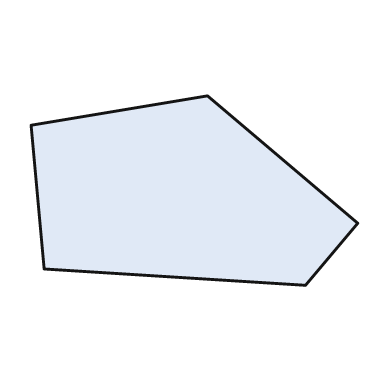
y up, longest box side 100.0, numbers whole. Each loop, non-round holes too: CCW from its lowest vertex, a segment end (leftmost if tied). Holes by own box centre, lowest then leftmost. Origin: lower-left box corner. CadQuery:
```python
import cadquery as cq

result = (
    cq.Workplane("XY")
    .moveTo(84.0, 0.0)
    .lineTo(100.0, 19.0)
    .lineTo(54.0, 58.0)
    .lineTo(0.0, 49.0)
    .lineTo(4.0, 5.0)
    .close()
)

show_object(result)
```